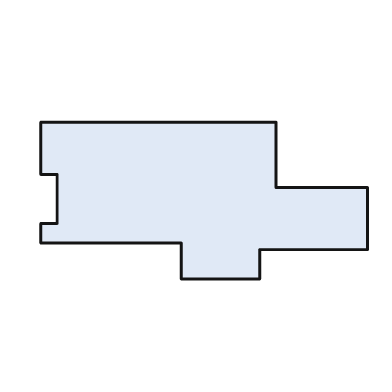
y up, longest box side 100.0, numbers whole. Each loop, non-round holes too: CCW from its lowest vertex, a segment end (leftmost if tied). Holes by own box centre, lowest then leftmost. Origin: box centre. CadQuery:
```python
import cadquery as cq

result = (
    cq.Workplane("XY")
    .moveTo(-7.0, -24.0)
    .lineTo(17.0, -24.0)
    .lineTo(17.0, -15.0)
    .lineTo(50.0, -15.0)
    .lineTo(50.0, 4.0)
    .lineTo(22.0, 4.0)
    .lineTo(22.0, 24.0)
    .lineTo(-50.0, 24.0)
    .lineTo(-50.0, 8.0)
    .lineTo(-45.0, 8.0)
    .lineTo(-45.0, -7.0)
    .lineTo(-50.0, -7.0)
    .lineTo(-50.0, -13.0)
    .lineTo(-7.0, -13.0)
    .close()
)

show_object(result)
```